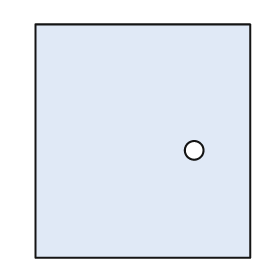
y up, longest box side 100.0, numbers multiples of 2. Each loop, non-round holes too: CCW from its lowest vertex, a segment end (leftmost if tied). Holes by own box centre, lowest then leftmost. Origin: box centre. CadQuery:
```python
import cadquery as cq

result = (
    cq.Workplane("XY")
    .moveTo(-46.0, -50.0)
    .lineTo(46.0, -50.0)
    .lineTo(46.0, 50.0)
    .lineTo(-46.0, 50.0)
    .close()
    .moveTo(22.0, -4.0)
    .circle(4.0)
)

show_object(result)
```